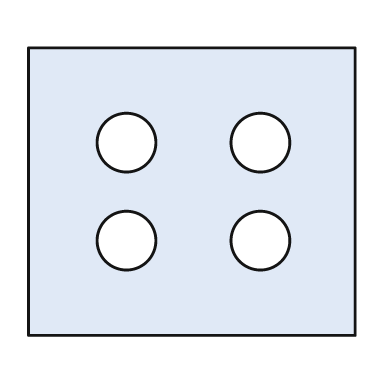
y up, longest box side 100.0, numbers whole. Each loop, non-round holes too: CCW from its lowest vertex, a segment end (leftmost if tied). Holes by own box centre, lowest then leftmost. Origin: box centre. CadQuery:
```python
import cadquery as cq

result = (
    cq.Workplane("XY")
    .moveTo(-50.0, -44.0)
    .lineTo(50.0, -44.0)
    .lineTo(50.0, 44.0)
    .lineTo(-50.0, 44.0)
    .close()
    .moveTo(-20.0, -15.0)
    .circle(9.0)
    .moveTo(21.0, -15.0)
    .circle(9.0)
    .moveTo(-20.0, 15.0)
    .circle(9.0)
    .moveTo(21.0, 15.0)
    .circle(9.0)
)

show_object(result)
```